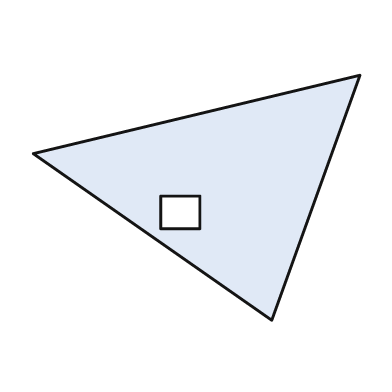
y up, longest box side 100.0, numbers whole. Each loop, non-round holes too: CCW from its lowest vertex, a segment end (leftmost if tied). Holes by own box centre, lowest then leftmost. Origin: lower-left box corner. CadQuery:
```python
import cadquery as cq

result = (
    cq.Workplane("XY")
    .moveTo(73.0, 0.0)
    .lineTo(100.0, 75.0)
    .lineTo(0.0, 51.0)
    .close()
    .moveTo(39.0, 28.0)
    .lineTo(51.0, 28.0)
    .lineTo(51.0, 38.0)
    .lineTo(39.0, 38.0)
    .close()
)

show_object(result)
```